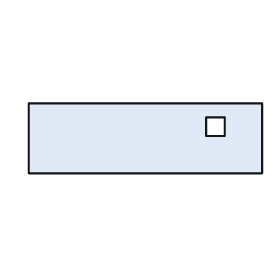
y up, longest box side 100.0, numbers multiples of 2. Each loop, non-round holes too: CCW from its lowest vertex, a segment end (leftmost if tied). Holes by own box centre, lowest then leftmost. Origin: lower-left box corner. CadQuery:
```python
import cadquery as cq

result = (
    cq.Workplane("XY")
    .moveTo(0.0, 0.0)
    .lineTo(100.0, 0.0)
    .lineTo(100.0, 30.0)
    .lineTo(0.0, 30.0)
    .close()
    .moveTo(76.0, 16.0)
    .lineTo(84.0, 16.0)
    .lineTo(84.0, 24.0)
    .lineTo(76.0, 24.0)
    .close()
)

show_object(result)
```